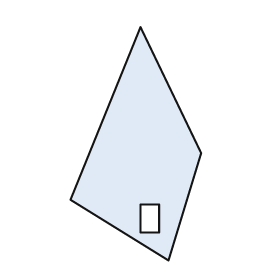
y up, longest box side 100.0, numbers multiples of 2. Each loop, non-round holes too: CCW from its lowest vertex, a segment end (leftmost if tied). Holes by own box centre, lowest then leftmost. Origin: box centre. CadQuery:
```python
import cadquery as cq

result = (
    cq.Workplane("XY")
    .moveTo(14.0, -50.0)
    .lineTo(28.0, -4.0)
    .lineTo(2.0, 50.0)
    .lineTo(-28.0, -24.0)
    .close()
    .moveTo(2.0, -38.0)
    .lineTo(10.0, -38.0)
    .lineTo(10.0, -26.0)
    .lineTo(2.0, -26.0)
    .close()
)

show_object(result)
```